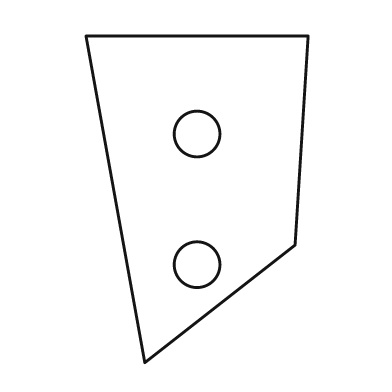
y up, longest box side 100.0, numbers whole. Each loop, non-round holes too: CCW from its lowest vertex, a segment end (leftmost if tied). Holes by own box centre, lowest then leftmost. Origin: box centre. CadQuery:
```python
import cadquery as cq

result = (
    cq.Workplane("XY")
    .moveTo(-16.0, -50.0)
    .lineTo(30.0, -14.0)
    .lineTo(34.0, 50.0)
    .lineTo(-34.0, 50.0)
    .close()
    .moveTo(0.0, -20.0)
    .circle(7.0)
    .moveTo(0.0, 20.0)
    .circle(7.0)
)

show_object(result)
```